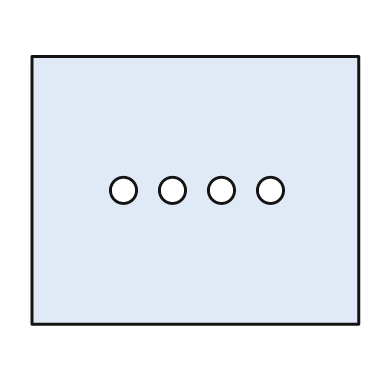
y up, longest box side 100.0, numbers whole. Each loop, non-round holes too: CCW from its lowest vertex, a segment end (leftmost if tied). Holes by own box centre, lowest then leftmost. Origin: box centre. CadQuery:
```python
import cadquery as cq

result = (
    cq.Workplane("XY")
    .moveTo(-50.0, -41.0)
    .lineTo(50.0, -41.0)
    .lineTo(50.0, 41.0)
    .lineTo(-50.0, 41.0)
    .close()
    .moveTo(-22.0, 0.0)
    .circle(4.0)
    .moveTo(-7.0, 0.0)
    .circle(4.0)
    .moveTo(8.0, 0.0)
    .circle(4.0)
    .moveTo(23.0, 0.0)
    .circle(4.0)
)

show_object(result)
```